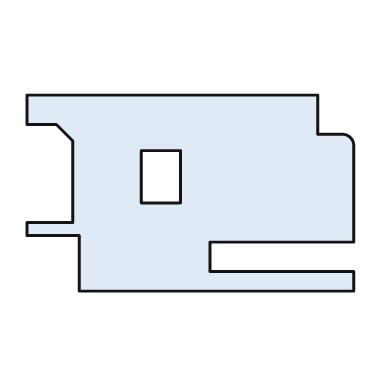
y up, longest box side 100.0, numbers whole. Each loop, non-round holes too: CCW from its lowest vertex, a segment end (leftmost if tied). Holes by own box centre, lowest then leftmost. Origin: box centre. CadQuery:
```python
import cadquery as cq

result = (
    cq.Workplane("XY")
    .moveTo(-34.0, -30.0)
    .lineTo(50.0, -30.0)
    .lineTo(50.0, -24.0)
    .lineTo(6.0, -24.0)
    .lineTo(6.0, -15.0)
    .lineTo(50.0, -15.0)
    .lineTo(50.0, 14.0)
    .threePointArc((49.0, 17.0), (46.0, 18.0))
    .lineTo(39.0, 18.0)
    .lineTo(39.0, 30.0)
    .lineTo(-50.0, 30.0)
    .lineTo(-50.0, 21.0)
    .lineTo(-41.0, 21.0)
    .lineTo(-36.0, 16.0)
    .lineTo(-36.0, -9.0)
    .lineTo(-50.0, -9.0)
    .lineTo(-50.0, -13.0)
    .lineTo(-34.0, -13.0)
    .close()
    .moveTo(-15.0, -3.0)
    .lineTo(-3.0, -3.0)
    .lineTo(-3.0, 13.0)
    .lineTo(-15.0, 13.0)
    .close()
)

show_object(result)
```